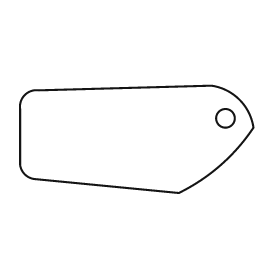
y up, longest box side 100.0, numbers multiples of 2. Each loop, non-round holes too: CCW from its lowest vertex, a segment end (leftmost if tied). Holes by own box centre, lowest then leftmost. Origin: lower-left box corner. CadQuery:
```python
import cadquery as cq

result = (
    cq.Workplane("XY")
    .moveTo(68.0, 0.0)
    .threePointArc((86.0, 12.0), (100.0, 28.0))
    .threePointArc((94.0, 40.0), (82.0, 46.0))
    .lineTo(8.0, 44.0)
    .threePointArc((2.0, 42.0), (0.0, 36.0))
    .lineTo(0.0, 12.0)
    .threePointArc((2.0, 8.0), (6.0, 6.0))
    .close()
    .moveTo(88.0, 32.0)
    .circle(4.0)
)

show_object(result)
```